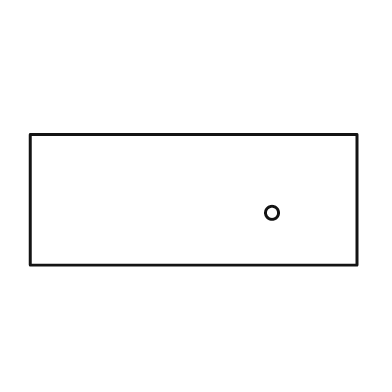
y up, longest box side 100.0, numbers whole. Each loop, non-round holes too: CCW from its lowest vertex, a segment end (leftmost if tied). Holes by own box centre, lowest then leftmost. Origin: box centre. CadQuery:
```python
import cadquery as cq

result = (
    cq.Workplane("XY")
    .moveTo(-50.0, -20.0)
    .lineTo(50.0, -20.0)
    .lineTo(50.0, 20.0)
    .lineTo(-50.0, 20.0)
    .close()
    .moveTo(24.0, -4.0)
    .circle(2.0)
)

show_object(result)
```